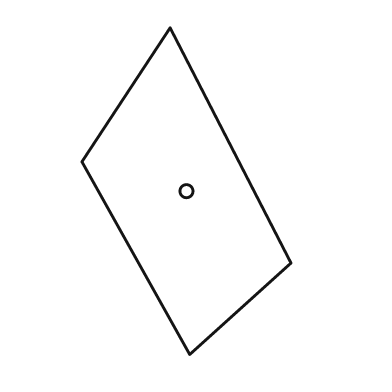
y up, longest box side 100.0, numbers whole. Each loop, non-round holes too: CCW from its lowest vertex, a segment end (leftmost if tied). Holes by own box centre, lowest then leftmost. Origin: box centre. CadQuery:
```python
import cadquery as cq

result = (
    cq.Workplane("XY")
    .moveTo(1.0, -50.0)
    .lineTo(32.0, -22.0)
    .lineTo(-5.0, 50.0)
    .lineTo(-32.0, 9.0)
    .close()
    .moveTo(0.0, 0.0)
    .circle(2.0)
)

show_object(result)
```